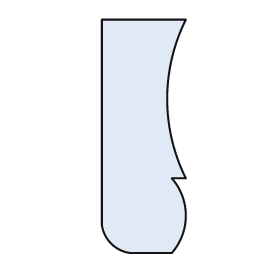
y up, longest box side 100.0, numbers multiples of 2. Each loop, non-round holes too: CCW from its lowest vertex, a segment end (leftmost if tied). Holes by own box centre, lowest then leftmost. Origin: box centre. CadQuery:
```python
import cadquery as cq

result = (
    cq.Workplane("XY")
    .moveTo(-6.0, -50.0)
    .lineTo(12.0, -50.0)
    .threePointArc((18.0, -34.0), (12.0, -18.0))
    .lineTo(18.0, -18.0)
    .threePointArc((10.0, 16.0), (18.0, 50.0))
    .lineTo(-18.0, 50.0)
    .lineTo(-18.0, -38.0)
    .threePointArc((-14.0, -46.0), (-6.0, -50.0))
    .close()
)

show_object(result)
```